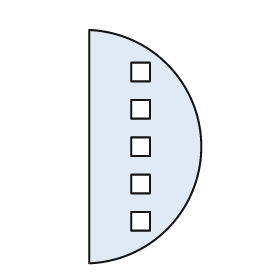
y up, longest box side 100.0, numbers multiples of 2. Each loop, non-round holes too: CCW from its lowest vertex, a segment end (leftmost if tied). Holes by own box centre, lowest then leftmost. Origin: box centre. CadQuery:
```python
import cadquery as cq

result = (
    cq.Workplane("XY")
    .moveTo(-24.0, -50.0)
    .threePointArc((24.0, 0.0), (-24.0, 50.0))
    .close()
    .moveTo(-6.0, -36.0)
    .lineTo(2.0, -36.0)
    .lineTo(2.0, -28.0)
    .lineTo(-6.0, -28.0)
    .close()
    .moveTo(-6.0, -20.0)
    .lineTo(2.0, -20.0)
    .lineTo(2.0, -12.0)
    .lineTo(-6.0, -12.0)
    .close()
    .moveTo(-6.0, -4.0)
    .lineTo(2.0, -4.0)
    .lineTo(2.0, 4.0)
    .lineTo(-6.0, 4.0)
    .close()
    .moveTo(-6.0, 12.0)
    .lineTo(2.0, 12.0)
    .lineTo(2.0, 20.0)
    .lineTo(-6.0, 20.0)
    .close()
    .moveTo(-6.0, 28.0)
    .lineTo(2.0, 28.0)
    .lineTo(2.0, 36.0)
    .lineTo(-6.0, 36.0)
    .close()
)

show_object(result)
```